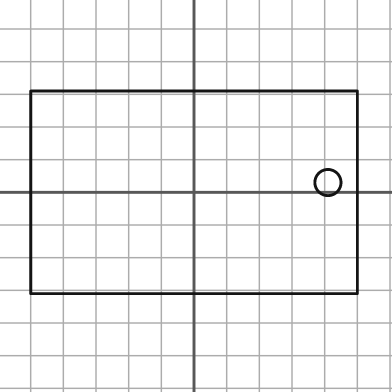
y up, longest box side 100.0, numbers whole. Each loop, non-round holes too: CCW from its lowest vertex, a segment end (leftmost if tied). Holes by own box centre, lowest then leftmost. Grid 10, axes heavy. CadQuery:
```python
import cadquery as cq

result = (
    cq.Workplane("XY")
    .moveTo(-50.0, -31.0)
    .lineTo(50.0, -31.0)
    .lineTo(50.0, 31.0)
    .lineTo(-50.0, 31.0)
    .close()
    .moveTo(41.0, 3.0)
    .circle(4.0)
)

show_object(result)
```